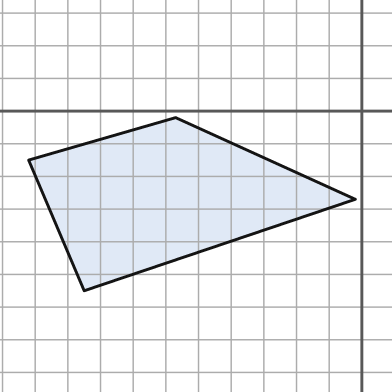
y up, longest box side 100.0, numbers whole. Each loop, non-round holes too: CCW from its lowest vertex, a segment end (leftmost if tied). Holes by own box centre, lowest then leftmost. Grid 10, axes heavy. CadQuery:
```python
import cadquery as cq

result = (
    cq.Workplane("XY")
    .moveTo(-85.0, -55.0)
    .lineTo(-2.0, -27.0)
    .lineTo(-57.0, -2.0)
    .lineTo(-102.0, -15.0)
    .close()
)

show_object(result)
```